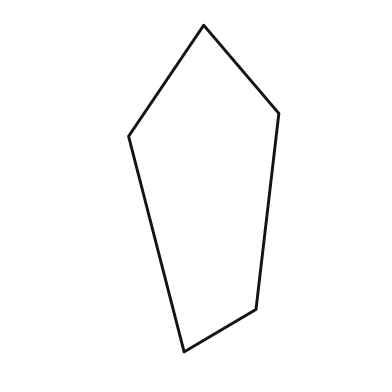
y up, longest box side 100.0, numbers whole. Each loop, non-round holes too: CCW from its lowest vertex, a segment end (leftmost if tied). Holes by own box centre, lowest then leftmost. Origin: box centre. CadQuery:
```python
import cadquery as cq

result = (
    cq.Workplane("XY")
    .moveTo(-6.0, -50.0)
    .lineTo(16.0, -37.0)
    .lineTo(23.0, 23.0)
    .lineTo(0.0, 50.0)
    .lineTo(-23.0, 16.0)
    .close()
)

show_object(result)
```